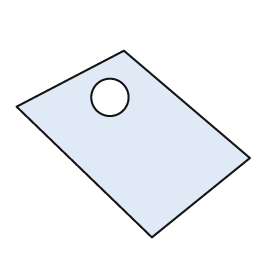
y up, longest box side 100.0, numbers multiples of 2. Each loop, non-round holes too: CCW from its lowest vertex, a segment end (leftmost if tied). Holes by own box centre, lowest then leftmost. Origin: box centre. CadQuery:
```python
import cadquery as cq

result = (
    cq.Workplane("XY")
    .moveTo(8.0, -40.0)
    .lineTo(50.0, -6.0)
    .lineTo(-4.0, 40.0)
    .lineTo(-50.0, 16.0)
    .close()
    .moveTo(-10.0, 20.0)
    .circle(8.0)
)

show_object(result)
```